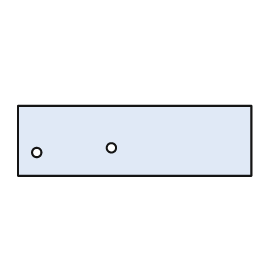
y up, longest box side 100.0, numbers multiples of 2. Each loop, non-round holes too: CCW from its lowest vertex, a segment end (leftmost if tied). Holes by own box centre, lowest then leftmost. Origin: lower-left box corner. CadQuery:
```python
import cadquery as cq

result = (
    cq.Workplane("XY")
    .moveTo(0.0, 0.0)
    .lineTo(100.0, 0.0)
    .lineTo(100.0, 30.0)
    .lineTo(0.0, 30.0)
    .close()
    .moveTo(8.0, 10.0)
    .circle(2.0)
    .moveTo(40.0, 12.0)
    .circle(2.0)
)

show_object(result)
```